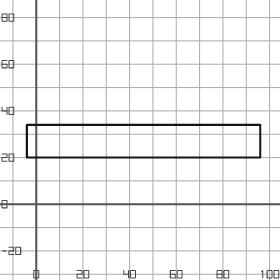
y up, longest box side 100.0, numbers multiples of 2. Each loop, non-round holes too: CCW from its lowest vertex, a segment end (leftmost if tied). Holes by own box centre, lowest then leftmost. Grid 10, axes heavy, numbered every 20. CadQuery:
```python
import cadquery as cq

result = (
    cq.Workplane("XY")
    .moveTo(-4.0, 20.0)
    .lineTo(96.0, 20.0)
    .lineTo(96.0, 34.0)
    .lineTo(-4.0, 34.0)
    .close()
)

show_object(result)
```